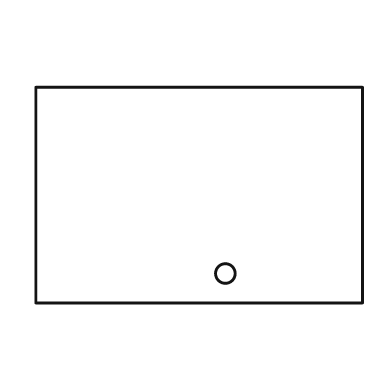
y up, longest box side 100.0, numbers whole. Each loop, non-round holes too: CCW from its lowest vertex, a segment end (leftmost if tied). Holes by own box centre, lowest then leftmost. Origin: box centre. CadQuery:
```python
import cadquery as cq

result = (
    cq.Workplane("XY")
    .moveTo(-50.0, -33.0)
    .lineTo(50.0, -33.0)
    .lineTo(50.0, 33.0)
    .lineTo(-50.0, 33.0)
    .close()
    .moveTo(8.0, -24.0)
    .circle(3.0)
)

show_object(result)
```